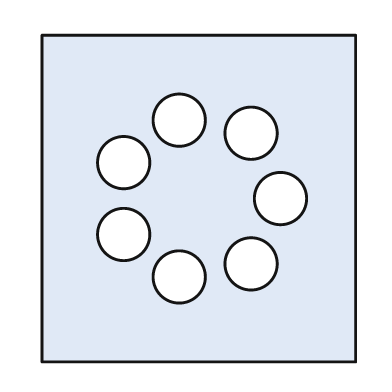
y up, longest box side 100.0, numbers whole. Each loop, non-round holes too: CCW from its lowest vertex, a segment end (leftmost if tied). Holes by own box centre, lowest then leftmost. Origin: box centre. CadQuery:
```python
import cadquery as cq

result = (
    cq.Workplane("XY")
    .moveTo(-48.0, -50.0)
    .lineTo(48.0, -50.0)
    .lineTo(48.0, 50.0)
    .lineTo(-48.0, 50.0)
    .close()
    .moveTo(-6.0, -24.0)
    .circle(8.0)
    .moveTo(16.0, -20.0)
    .circle(8.0)
    .moveTo(-23.0, -11.0)
    .circle(8.0)
    .moveTo(25.0, 0.0)
    .circle(8.0)
    .moveTo(-23.0, 11.0)
    .circle(8.0)
    .moveTo(16.0, 20.0)
    .circle(8.0)
    .moveTo(-6.0, 24.0)
    .circle(8.0)
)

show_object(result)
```